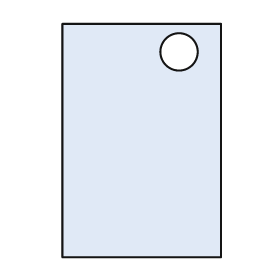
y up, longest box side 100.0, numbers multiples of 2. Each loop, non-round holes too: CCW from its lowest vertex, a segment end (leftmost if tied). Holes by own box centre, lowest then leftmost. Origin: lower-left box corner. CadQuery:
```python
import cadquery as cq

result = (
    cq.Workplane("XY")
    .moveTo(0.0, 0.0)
    .lineTo(68.0, 0.0)
    .lineTo(68.0, 100.0)
    .lineTo(0.0, 100.0)
    .close()
    .moveTo(50.0, 88.0)
    .circle(8.0)
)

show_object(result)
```